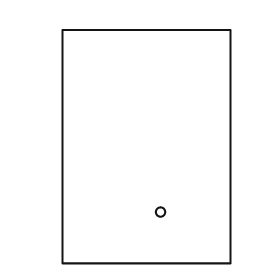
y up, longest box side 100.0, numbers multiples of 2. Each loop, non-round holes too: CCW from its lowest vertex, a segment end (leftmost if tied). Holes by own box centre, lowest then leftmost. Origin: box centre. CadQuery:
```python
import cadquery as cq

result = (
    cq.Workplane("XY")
    .moveTo(-36.0, -50.0)
    .lineTo(36.0, -50.0)
    .lineTo(36.0, 50.0)
    .lineTo(-36.0, 50.0)
    .close()
    .moveTo(6.0, -28.0)
    .circle(2.0)
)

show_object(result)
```